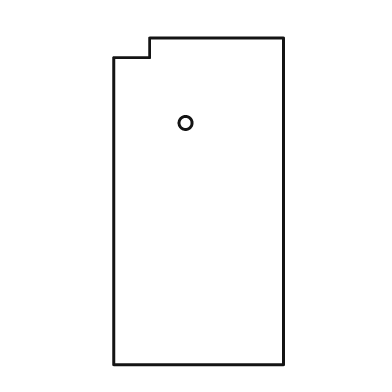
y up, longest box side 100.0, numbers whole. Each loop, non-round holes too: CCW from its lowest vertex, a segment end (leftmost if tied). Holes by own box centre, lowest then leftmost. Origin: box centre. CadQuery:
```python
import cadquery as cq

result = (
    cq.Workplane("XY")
    .moveTo(-26.0, -50.0)
    .lineTo(26.0, -50.0)
    .lineTo(26.0, 50.0)
    .lineTo(-15.0, 50.0)
    .lineTo(-15.0, 44.0)
    .lineTo(-26.0, 44.0)
    .close()
    .moveTo(-4.0, 24.0)
    .circle(2.0)
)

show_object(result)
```